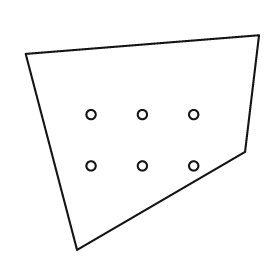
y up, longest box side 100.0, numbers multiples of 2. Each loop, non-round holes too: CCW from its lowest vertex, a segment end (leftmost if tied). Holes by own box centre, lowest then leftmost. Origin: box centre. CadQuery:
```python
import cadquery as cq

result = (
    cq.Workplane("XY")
    .moveTo(-28.0, -46.0)
    .lineTo(44.0, -4.0)
    .lineTo(50.0, 46.0)
    .lineTo(-50.0, 38.0)
    .close()
    .moveTo(-22.0, -10.0)
    .circle(2.0)
    .moveTo(0.0, -10.0)
    .circle(2.0)
    .moveTo(22.0, -10.0)
    .circle(2.0)
    .moveTo(-22.0, 12.0)
    .circle(2.0)
    .moveTo(0.0, 12.0)
    .circle(2.0)
    .moveTo(22.0, 12.0)
    .circle(2.0)
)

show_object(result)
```